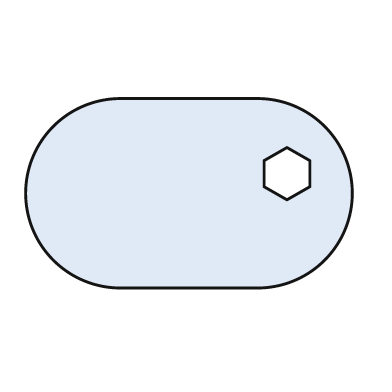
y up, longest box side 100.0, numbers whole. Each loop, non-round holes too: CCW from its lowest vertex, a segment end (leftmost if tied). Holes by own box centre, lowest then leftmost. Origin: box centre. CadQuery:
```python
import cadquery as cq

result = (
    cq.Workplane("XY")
    .moveTo(-21.0, -29.0)
    .lineTo(21.0, -29.0)
    .threePointArc((50.0, 0.0), (21.0, 29.0))
    .lineTo(-21.0, 29.0)
    .threePointArc((-50.0, 0.0), (-21.0, -29.0))
    .close()
    .moveTo(30.0, -2.0)
    .lineTo(37.0, 2.0)
    .lineTo(37.0, 10.0)
    .lineTo(30.0, 14.0)
    .lineTo(23.0, 10.0)
    .lineTo(23.0, 2.0)
    .close()
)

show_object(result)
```